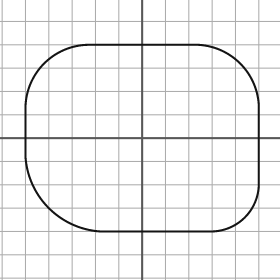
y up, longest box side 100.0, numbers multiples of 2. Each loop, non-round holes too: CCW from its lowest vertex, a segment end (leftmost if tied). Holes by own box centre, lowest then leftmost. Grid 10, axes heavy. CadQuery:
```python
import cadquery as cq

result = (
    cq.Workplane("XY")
    .moveTo(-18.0, -40.0)
    .lineTo(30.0, -40.0)
    .threePointArc((44.0, -34.0), (50.0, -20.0))
    .lineTo(50.0, 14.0)
    .threePointArc((42.0, 32.0), (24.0, 40.0))
    .lineTo(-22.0, 40.0)
    .threePointArc((-42.0, 32.0), (-50.0, 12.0))
    .lineTo(-50.0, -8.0)
    .threePointArc((-40.0, -30.0), (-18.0, -40.0))
    .close()
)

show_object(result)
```